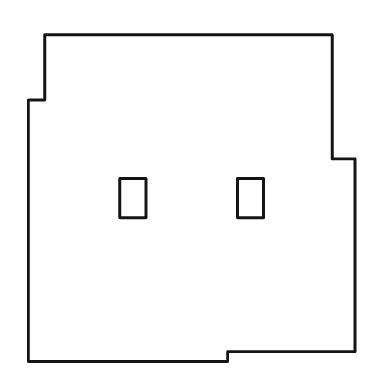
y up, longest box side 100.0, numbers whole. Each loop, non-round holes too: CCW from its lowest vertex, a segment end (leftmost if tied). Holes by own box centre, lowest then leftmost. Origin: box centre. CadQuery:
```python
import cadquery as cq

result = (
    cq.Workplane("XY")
    .moveTo(-50.0, -50.0)
    .lineTo(11.0, -50.0)
    .lineTo(11.0, -47.0)
    .lineTo(50.0, -47.0)
    .lineTo(50.0, 12.0)
    .lineTo(43.0, 12.0)
    .lineTo(43.0, 50.0)
    .lineTo(-45.0, 50.0)
    .lineTo(-45.0, 30.0)
    .lineTo(-50.0, 30.0)
    .close()
    .moveTo(-22.0, -6.0)
    .lineTo(-14.0, -6.0)
    .lineTo(-14.0, 6.0)
    .lineTo(-22.0, 6.0)
    .close()
    .moveTo(14.0, -6.0)
    .lineTo(22.0, -6.0)
    .lineTo(22.0, 6.0)
    .lineTo(14.0, 6.0)
    .close()
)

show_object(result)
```